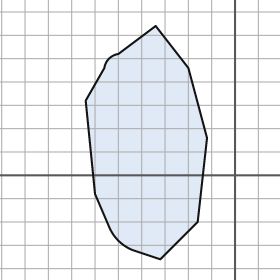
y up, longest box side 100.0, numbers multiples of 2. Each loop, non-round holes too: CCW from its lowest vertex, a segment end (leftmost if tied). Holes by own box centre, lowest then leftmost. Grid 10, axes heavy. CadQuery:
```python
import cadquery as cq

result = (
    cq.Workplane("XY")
    .moveTo(-32.0, -36.0)
    .lineTo(-16.0, -20.0)
    .lineTo(-12.0, 16.0)
    .lineTo(-20.0, 46.0)
    .lineTo(-34.0, 64.0)
    .lineTo(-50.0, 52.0)
    .threePointArc((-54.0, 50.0), (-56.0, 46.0))
    .lineTo(-64.0, 32.0)
    .lineTo(-60.0, -8.0)
    .lineTo(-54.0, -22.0)
    .threePointArc((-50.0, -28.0), (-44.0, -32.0))
    .close()
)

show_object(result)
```